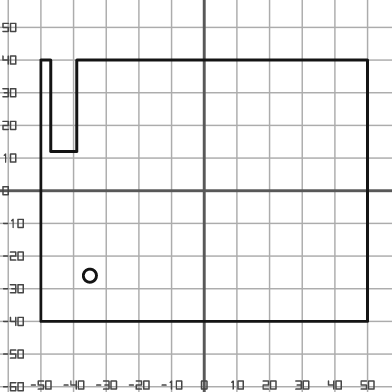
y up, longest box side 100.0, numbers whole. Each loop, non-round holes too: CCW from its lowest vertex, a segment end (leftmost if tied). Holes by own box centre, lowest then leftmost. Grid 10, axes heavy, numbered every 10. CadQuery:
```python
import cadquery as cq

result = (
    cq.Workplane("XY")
    .moveTo(-50.0, -40.0)
    .lineTo(50.0, -40.0)
    .lineTo(50.0, 40.0)
    .lineTo(-39.0, 40.0)
    .lineTo(-39.0, 12.0)
    .lineTo(-47.0, 12.0)
    .lineTo(-47.0, 40.0)
    .lineTo(-50.0, 40.0)
    .close()
    .moveTo(-35.0, -26.0)
    .circle(2.0)
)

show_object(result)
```